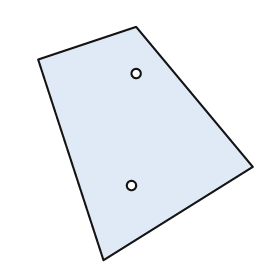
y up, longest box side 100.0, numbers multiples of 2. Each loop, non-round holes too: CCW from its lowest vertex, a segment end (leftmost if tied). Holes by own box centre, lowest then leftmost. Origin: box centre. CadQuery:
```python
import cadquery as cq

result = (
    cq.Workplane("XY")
    .moveTo(-18.0, -50.0)
    .lineTo(46.0, -10.0)
    .lineTo(-4.0, 50.0)
    .lineTo(-46.0, 36.0)
    .close()
    .moveTo(-6.0, -18.0)
    .circle(2.0)
    .moveTo(-4.0, 30.0)
    .circle(2.0)
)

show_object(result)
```